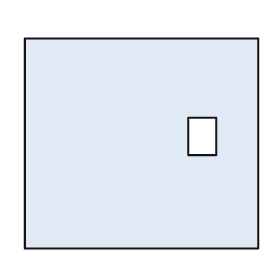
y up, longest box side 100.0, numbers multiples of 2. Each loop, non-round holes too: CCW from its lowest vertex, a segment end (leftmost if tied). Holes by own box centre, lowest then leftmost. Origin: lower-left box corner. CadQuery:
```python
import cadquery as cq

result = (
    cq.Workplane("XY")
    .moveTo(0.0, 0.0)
    .lineTo(100.0, 0.0)
    .lineTo(100.0, 90.0)
    .lineTo(0.0, 90.0)
    .close()
    .moveTo(70.0, 40.0)
    .lineTo(82.0, 40.0)
    .lineTo(82.0, 56.0)
    .lineTo(70.0, 56.0)
    .close()
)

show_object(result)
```